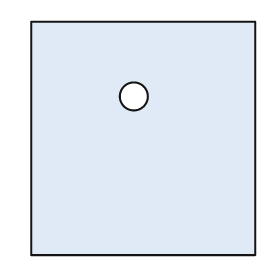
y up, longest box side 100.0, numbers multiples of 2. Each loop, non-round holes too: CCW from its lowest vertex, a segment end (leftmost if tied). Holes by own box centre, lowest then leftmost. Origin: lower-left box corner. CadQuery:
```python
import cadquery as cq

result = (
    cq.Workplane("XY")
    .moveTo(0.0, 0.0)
    .lineTo(96.0, 0.0)
    .lineTo(96.0, 100.0)
    .lineTo(0.0, 100.0)
    .close()
    .moveTo(44.0, 68.0)
    .circle(6.0)
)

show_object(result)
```